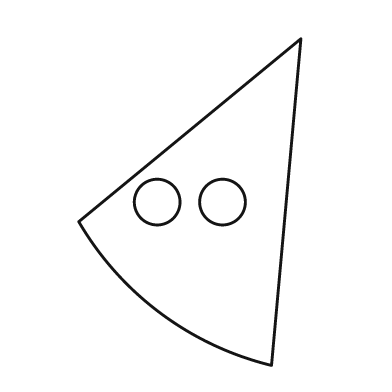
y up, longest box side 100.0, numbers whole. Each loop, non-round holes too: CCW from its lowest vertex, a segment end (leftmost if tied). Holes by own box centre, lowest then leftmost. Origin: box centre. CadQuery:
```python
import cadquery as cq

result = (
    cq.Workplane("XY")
    .moveTo(25.0, -50.0)
    .lineTo(34.0, 50.0)
    .lineTo(-34.0, -6.0)
    .threePointArc((-9.0, -34.0), (25.0, -50.0))
    .close()
    .moveTo(-10.0, 0.0)
    .circle(7.0)
    .moveTo(10.0, 0.0)
    .circle(7.0)
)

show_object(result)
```